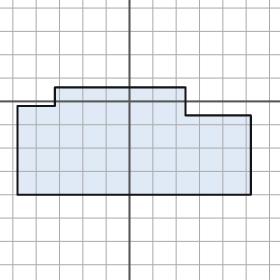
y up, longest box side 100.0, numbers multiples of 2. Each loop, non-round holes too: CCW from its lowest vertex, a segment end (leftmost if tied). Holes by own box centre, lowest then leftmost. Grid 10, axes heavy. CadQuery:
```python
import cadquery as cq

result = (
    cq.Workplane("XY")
    .moveTo(-48.0, -40.0)
    .lineTo(52.0, -40.0)
    .lineTo(52.0, -6.0)
    .lineTo(24.0, -6.0)
    .lineTo(24.0, 6.0)
    .lineTo(-32.0, 6.0)
    .lineTo(-32.0, -2.0)
    .lineTo(-48.0, -2.0)
    .close()
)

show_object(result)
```